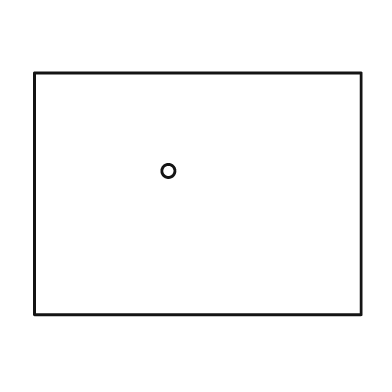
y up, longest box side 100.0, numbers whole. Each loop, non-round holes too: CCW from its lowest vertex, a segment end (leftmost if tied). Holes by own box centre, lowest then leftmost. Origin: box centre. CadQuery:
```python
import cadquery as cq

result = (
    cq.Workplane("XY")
    .moveTo(-50.0, -37.0)
    .lineTo(50.0, -37.0)
    .lineTo(50.0, 37.0)
    .lineTo(-50.0, 37.0)
    .close()
    .moveTo(-9.0, 7.0)
    .circle(2.0)
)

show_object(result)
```